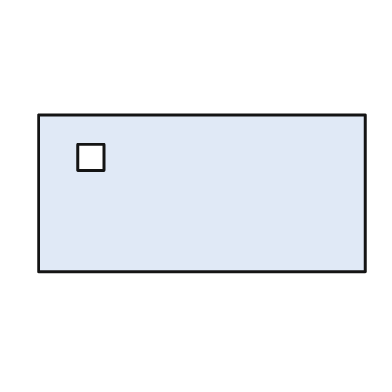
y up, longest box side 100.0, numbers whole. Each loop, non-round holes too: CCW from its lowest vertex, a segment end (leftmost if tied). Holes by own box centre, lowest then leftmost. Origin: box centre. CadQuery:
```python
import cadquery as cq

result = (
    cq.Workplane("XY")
    .moveTo(-50.0, -24.0)
    .lineTo(50.0, -24.0)
    .lineTo(50.0, 24.0)
    .lineTo(-50.0, 24.0)
    .close()
    .moveTo(-38.0, 7.0)
    .lineTo(-30.0, 7.0)
    .lineTo(-30.0, 15.0)
    .lineTo(-38.0, 15.0)
    .close()
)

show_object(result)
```